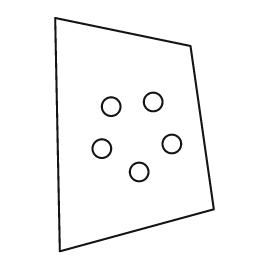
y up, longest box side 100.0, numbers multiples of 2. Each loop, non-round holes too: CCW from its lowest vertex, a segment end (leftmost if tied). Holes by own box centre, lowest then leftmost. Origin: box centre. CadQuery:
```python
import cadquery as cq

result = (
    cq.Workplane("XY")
    .moveTo(-32.0, -50.0)
    .lineTo(34.0, -32.0)
    .lineTo(24.0, 38.0)
    .lineTo(-34.0, 50.0)
    .close()
    .moveTo(2.0, -16.0)
    .circle(4.0)
    .moveTo(-14.0, -6.0)
    .circle(4.0)
    .moveTo(16.0, -4.0)
    .circle(4.0)
    .moveTo(-10.0, 12.0)
    .circle(4.0)
    .moveTo(8.0, 14.0)
    .circle(4.0)
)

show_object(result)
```